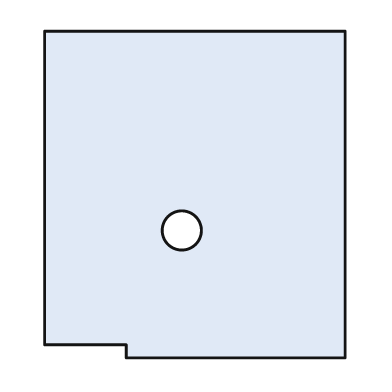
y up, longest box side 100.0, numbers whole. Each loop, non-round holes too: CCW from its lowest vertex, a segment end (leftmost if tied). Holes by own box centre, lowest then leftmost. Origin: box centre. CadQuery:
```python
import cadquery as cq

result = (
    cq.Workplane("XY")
    .moveTo(-21.0, -50.0)
    .lineTo(46.0, -50.0)
    .lineTo(46.0, 50.0)
    .lineTo(-46.0, 50.0)
    .lineTo(-46.0, -46.0)
    .lineTo(-21.0, -46.0)
    .close()
    .moveTo(-4.0, -11.0)
    .circle(6.0)
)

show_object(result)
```